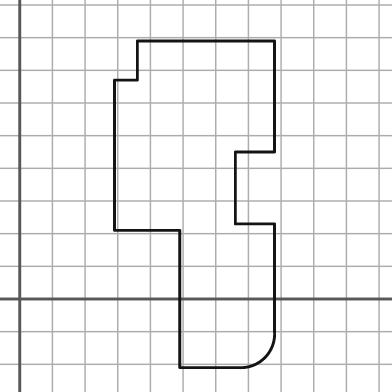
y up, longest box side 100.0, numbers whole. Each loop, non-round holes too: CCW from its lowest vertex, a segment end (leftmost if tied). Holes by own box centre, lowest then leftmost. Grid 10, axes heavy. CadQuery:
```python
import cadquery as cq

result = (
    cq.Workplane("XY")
    .moveTo(49.0, -21.0)
    .lineTo(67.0, -21.0)
    .threePointArc((75.0, -18.0), (78.0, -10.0))
    .lineTo(78.0, 23.0)
    .lineTo(66.0, 23.0)
    .lineTo(66.0, 45.0)
    .lineTo(78.0, 45.0)
    .lineTo(78.0, 79.0)
    .lineTo(36.0, 79.0)
    .lineTo(36.0, 67.0)
    .lineTo(29.0, 67.0)
    .lineTo(29.0, 21.0)
    .lineTo(49.0, 21.0)
    .close()
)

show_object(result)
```